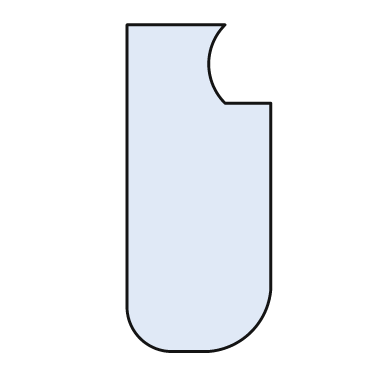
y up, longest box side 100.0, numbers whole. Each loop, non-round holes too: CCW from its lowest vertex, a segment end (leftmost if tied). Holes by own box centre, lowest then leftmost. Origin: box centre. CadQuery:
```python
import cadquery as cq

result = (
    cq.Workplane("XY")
    .moveTo(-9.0, -50.0)
    .lineTo(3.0, -50.0)
    .threePointArc((16.0, -44.0), (22.0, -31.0))
    .lineTo(22.0, 26.0)
    .lineTo(8.0, 26.0)
    .threePointArc((3.0, 38.0), (8.0, 50.0))
    .lineTo(-22.0, 50.0)
    .lineTo(-22.0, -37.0)
    .threePointArc((-18.0, -46.0), (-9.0, -50.0))
    .close()
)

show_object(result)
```